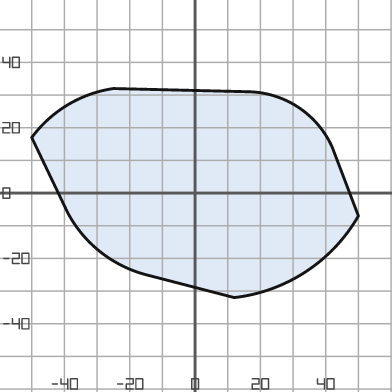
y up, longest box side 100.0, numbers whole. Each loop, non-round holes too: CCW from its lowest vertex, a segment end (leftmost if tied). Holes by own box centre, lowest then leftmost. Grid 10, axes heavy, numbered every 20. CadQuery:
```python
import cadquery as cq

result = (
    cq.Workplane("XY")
    .moveTo(12.0, -32.0)
    .threePointArc((34.0, -24.0), (50.0, -7.0))
    .lineTo(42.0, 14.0)
    .threePointArc((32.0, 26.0), (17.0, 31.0))
    .lineTo(-25.0, 32.0)
    .threePointArc((-39.0, 27.0), (-50.0, 17.0))
    .lineTo(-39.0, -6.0)
    .threePointArc((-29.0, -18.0), (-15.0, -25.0))
    .close()
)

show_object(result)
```